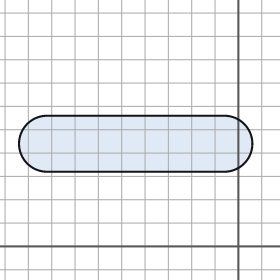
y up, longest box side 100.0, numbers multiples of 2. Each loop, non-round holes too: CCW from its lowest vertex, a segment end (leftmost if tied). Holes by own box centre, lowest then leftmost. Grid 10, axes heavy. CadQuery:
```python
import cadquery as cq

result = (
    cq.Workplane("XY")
    .moveTo(-82.0, 32.0)
    .lineTo(-6.0, 32.0)
    .threePointArc((6.0, 44.0), (-6.0, 56.0))
    .lineTo(-82.0, 56.0)
    .threePointArc((-94.0, 44.0), (-82.0, 32.0))
    .close()
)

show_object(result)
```